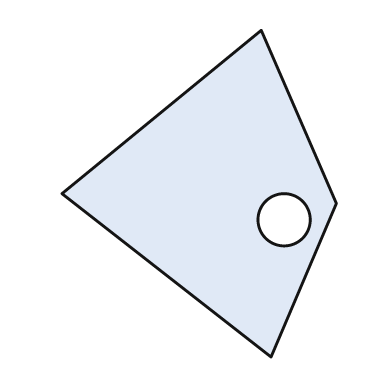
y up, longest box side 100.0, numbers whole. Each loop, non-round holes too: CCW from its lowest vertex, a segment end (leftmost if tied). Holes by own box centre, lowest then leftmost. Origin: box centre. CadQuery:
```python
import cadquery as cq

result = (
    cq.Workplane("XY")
    .moveTo(22.0, -50.0)
    .lineTo(42.0, -3.0)
    .lineTo(19.0, 50.0)
    .lineTo(-42.0, 0.0)
    .close()
    .moveTo(26.0, -8.0)
    .circle(8.0)
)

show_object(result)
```